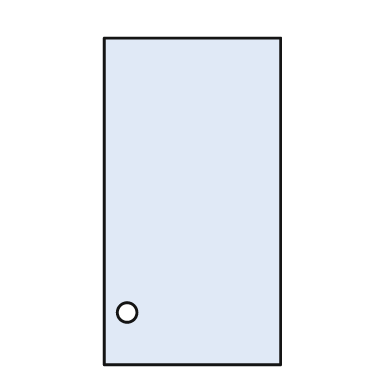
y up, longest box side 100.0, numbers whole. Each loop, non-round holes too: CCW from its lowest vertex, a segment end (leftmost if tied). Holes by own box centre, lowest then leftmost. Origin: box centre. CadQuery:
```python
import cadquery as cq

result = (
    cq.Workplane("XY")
    .moveTo(-27.0, -50.0)
    .lineTo(27.0, -50.0)
    .lineTo(27.0, 50.0)
    .lineTo(-27.0, 50.0)
    .close()
    .moveTo(-20.0, -34.0)
    .circle(3.0)
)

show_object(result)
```